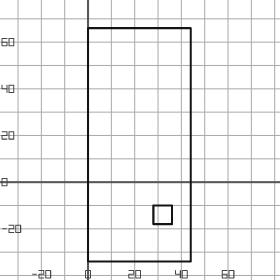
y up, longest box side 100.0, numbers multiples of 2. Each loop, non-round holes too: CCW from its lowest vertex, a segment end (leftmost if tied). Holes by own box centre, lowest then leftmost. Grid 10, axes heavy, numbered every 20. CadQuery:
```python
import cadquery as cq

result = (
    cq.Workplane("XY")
    .moveTo(0.0, -34.0)
    .lineTo(44.0, -34.0)
    .lineTo(44.0, 66.0)
    .lineTo(0.0, 66.0)
    .close()
    .moveTo(28.0, -18.0)
    .lineTo(36.0, -18.0)
    .lineTo(36.0, -10.0)
    .lineTo(28.0, -10.0)
    .close()
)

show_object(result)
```